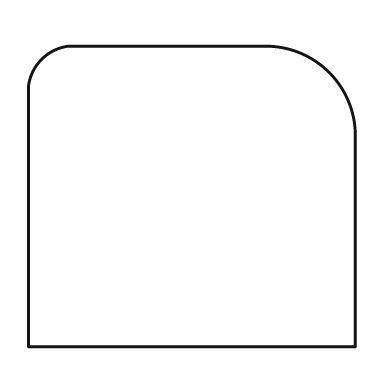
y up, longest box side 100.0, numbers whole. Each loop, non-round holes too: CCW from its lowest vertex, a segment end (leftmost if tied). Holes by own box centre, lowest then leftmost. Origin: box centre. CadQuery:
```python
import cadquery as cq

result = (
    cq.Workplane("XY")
    .moveTo(-50.0, -46.0)
    .lineTo(50.0, -46.0)
    .lineTo(50.0, 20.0)
    .threePointArc((42.0, 38.0), (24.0, 46.0))
    .lineTo(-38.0, 46.0)
    .threePointArc((-46.0, 42.0), (-50.0, 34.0))
    .close()
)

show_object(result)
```